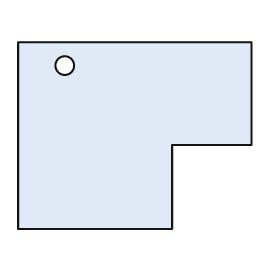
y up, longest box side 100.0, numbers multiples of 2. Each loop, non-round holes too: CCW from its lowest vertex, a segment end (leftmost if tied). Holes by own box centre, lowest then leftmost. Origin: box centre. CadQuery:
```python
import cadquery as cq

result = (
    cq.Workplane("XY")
    .moveTo(-50.0, -40.0)
    .lineTo(16.0, -40.0)
    .lineTo(16.0, -4.0)
    .lineTo(50.0, -4.0)
    .lineTo(50.0, 40.0)
    .lineTo(-50.0, 40.0)
    .close()
    .moveTo(-30.0, 30.0)
    .circle(4.0)
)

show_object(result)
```